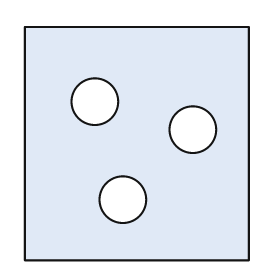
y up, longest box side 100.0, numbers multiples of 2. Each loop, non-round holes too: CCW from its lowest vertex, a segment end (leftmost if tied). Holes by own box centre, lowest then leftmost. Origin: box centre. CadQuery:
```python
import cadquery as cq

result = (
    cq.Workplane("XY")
    .moveTo(-48.0, -50.0)
    .lineTo(48.0, -50.0)
    .lineTo(48.0, 50.0)
    .lineTo(-48.0, 50.0)
    .close()
    .moveTo(-6.0, -24.0)
    .circle(10.0)
    .moveTo(24.0, 6.0)
    .circle(10.0)
    .moveTo(-18.0, 18.0)
    .circle(10.0)
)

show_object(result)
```